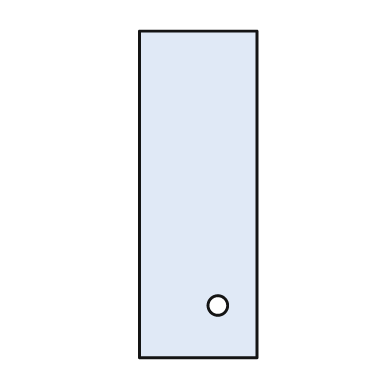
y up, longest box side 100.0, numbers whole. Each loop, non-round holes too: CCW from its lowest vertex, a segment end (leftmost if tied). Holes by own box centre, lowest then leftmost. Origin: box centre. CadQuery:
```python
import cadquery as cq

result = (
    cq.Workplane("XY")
    .moveTo(-18.0, -50.0)
    .lineTo(18.0, -50.0)
    .lineTo(18.0, 50.0)
    .lineTo(-18.0, 50.0)
    .close()
    .moveTo(6.0, -34.0)
    .circle(3.0)
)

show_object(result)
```